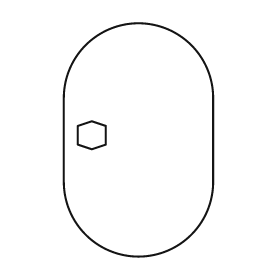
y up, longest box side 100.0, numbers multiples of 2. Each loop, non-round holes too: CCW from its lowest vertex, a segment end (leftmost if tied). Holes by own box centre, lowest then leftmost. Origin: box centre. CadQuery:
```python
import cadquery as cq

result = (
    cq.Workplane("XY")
    .moveTo(-32.0, -18.0)
    .threePointArc((0.0, -50.0), (32.0, -18.0))
    .lineTo(32.0, 18.0)
    .threePointArc((0.0, 50.0), (-32.0, 18.0))
    .close()
    .moveTo(-20.0, -4.0)
    .lineTo(-14.0, -2.0)
    .lineTo(-14.0, 6.0)
    .lineTo(-20.0, 8.0)
    .lineTo(-26.0, 6.0)
    .lineTo(-26.0, -2.0)
    .close()
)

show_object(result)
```